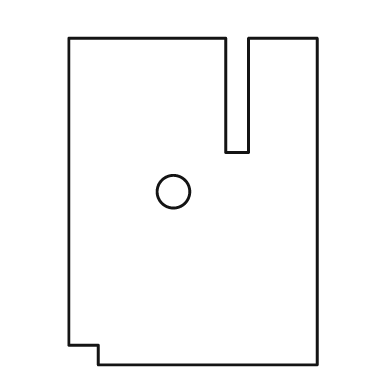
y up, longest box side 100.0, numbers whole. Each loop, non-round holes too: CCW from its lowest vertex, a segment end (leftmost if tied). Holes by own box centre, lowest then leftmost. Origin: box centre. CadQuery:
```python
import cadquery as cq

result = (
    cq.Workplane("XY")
    .moveTo(-29.0, -50.0)
    .lineTo(38.0, -50.0)
    .lineTo(38.0, 50.0)
    .lineTo(17.0, 50.0)
    .lineTo(17.0, 15.0)
    .lineTo(10.0, 15.0)
    .lineTo(10.0, 50.0)
    .lineTo(-38.0, 50.0)
    .lineTo(-38.0, -44.0)
    .lineTo(-29.0, -44.0)
    .close()
    .moveTo(-6.0, 3.0)
    .circle(5.0)
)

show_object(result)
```